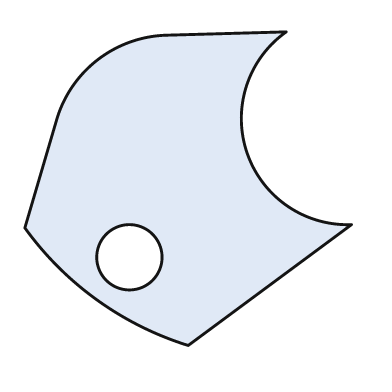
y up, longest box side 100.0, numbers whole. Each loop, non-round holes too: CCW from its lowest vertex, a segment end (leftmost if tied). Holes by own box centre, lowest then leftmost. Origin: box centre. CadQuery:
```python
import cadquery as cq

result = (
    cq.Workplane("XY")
    .moveTo(0.0, -48.0)
    .lineTo(50.0, -11.0)
    .threePointArc((18.0, 11.0), (30.0, 48.0))
    .lineTo(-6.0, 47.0)
    .threePointArc((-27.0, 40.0), (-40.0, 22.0))
    .lineTo(-50.0, -12.0)
    .threePointArc((-28.0, -34.0), (0.0, -48.0))
    .close()
    .moveTo(-18.0, -21.0)
    .circle(10.0)
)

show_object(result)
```